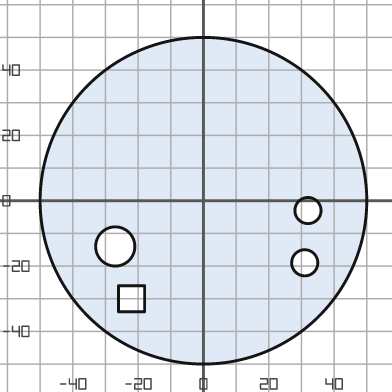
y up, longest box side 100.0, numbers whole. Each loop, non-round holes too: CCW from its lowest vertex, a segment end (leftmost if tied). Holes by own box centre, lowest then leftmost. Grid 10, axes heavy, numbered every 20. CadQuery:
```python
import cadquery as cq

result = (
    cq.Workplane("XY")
    .moveTo(0.0, 0.0)
    .circle(50.0)
    .moveTo(-26.0, -34.0)
    .lineTo(-18.0, -34.0)
    .lineTo(-18.0, -26.0)
    .lineTo(-26.0, -26.0)
    .close()
    .moveTo(31.0, -19.0)
    .circle(4.0)
    .moveTo(-27.0, -14.0)
    .circle(6.0)
    .moveTo(32.0, -3.0)
    .circle(4.0)
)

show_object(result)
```